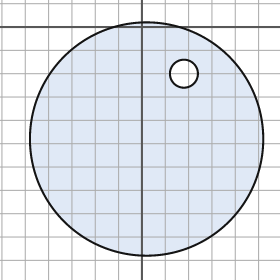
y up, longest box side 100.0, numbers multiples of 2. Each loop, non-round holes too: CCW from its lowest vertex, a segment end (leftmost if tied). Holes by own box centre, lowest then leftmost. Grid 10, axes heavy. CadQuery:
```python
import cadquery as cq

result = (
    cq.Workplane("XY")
    .moveTo(2.0, -48.0)
    .circle(50.0)
    .moveTo(18.0, -20.0)
    .circle(6.0)
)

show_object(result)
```